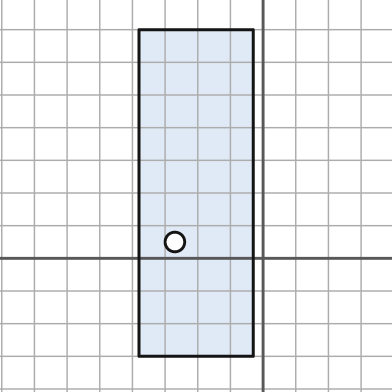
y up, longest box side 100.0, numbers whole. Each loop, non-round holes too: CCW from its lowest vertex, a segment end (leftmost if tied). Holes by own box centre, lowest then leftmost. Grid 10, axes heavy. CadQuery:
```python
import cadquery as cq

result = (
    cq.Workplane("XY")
    .moveTo(-38.0, -30.0)
    .lineTo(-3.0, -30.0)
    .lineTo(-3.0, 70.0)
    .lineTo(-38.0, 70.0)
    .close()
    .moveTo(-27.0, 5.0)
    .circle(3.0)
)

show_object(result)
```